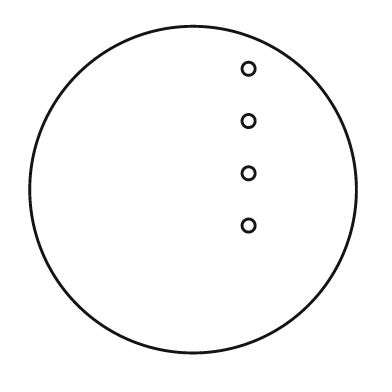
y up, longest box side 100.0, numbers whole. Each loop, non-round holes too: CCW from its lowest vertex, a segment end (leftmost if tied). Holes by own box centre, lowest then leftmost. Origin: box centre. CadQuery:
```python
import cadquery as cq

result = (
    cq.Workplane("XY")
    .moveTo(0.0, 0.0)
    .circle(50.0)
    .moveTo(17.0, -11.0)
    .circle(2.0)
    .moveTo(17.0, 5.0)
    .circle(2.0)
    .moveTo(17.0, 21.0)
    .circle(2.0)
    .moveTo(17.0, 37.0)
    .circle(2.0)
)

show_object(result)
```